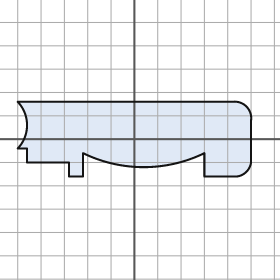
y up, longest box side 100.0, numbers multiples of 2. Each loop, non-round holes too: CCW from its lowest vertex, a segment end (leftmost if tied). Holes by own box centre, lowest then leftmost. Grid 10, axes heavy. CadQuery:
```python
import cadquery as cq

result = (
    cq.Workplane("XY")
    .moveTo(-28.0, -16.0)
    .lineTo(-22.0, -16.0)
    .lineTo(-22.0, -6.0)
    .threePointArc((4.0, -12.0), (30.0, -6.0))
    .lineTo(30.0, -16.0)
    .lineTo(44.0, -16.0)
    .threePointArc((48.0, -14.0), (50.0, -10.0))
    .lineTo(50.0, 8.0)
    .threePointArc((48.0, 14.0), (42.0, 16.0))
    .lineTo(-50.0, 16.0)
    .threePointArc((-46.0, 6.0), (-50.0, -4.0))
    .lineTo(-46.0, -4.0)
    .lineTo(-46.0, -10.0)
    .lineTo(-28.0, -10.0)
    .close()
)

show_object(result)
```